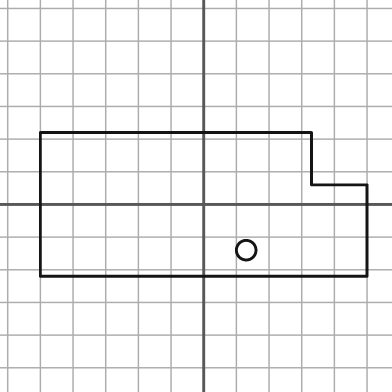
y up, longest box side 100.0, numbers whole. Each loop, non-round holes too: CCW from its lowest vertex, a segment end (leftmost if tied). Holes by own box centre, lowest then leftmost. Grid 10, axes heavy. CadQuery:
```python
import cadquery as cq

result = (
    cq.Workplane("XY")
    .moveTo(-50.0, -22.0)
    .lineTo(50.0, -22.0)
    .lineTo(50.0, 6.0)
    .lineTo(33.0, 6.0)
    .lineTo(33.0, 22.0)
    .lineTo(-50.0, 22.0)
    .close()
    .moveTo(13.0, -14.0)
    .circle(3.0)
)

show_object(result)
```